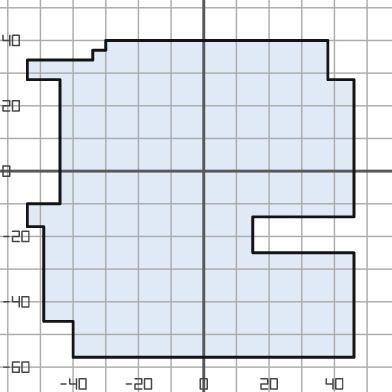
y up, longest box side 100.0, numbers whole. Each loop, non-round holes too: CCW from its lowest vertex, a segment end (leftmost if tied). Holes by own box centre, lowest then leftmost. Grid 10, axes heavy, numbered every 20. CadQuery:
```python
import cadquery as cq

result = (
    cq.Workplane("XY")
    .moveTo(-40.0, -57.0)
    .lineTo(46.0, -57.0)
    .lineTo(46.0, -25.0)
    .lineTo(15.0, -25.0)
    .lineTo(15.0, -14.0)
    .lineTo(46.0, -14.0)
    .lineTo(46.0, 28.0)
    .lineTo(38.0, 28.0)
    .lineTo(38.0, 40.0)
    .lineTo(-30.0, 40.0)
    .lineTo(-30.0, 37.0)
    .lineTo(-34.0, 37.0)
    .lineTo(-34.0, 34.0)
    .lineTo(-54.0, 34.0)
    .lineTo(-54.0, 28.0)
    .lineTo(-44.0, 28.0)
    .lineTo(-44.0, -10.0)
    .lineTo(-54.0, -10.0)
    .lineTo(-54.0, -17.0)
    .lineTo(-49.0, -17.0)
    .lineTo(-49.0, -46.0)
    .lineTo(-40.0, -46.0)
    .close()
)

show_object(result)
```